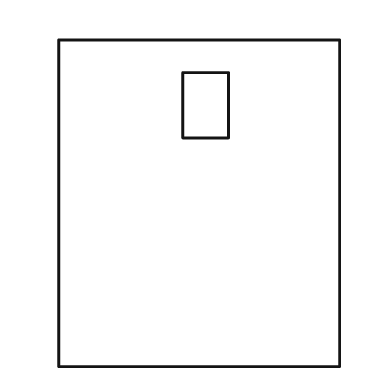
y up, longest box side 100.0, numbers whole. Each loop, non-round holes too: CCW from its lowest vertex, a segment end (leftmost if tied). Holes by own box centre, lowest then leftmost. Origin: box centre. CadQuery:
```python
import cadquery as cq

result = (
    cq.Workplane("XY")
    .moveTo(-43.0, -50.0)
    .lineTo(43.0, -50.0)
    .lineTo(43.0, 50.0)
    .lineTo(-43.0, 50.0)
    .close()
    .moveTo(-5.0, 20.0)
    .lineTo(9.0, 20.0)
    .lineTo(9.0, 40.0)
    .lineTo(-5.0, 40.0)
    .close()
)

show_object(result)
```